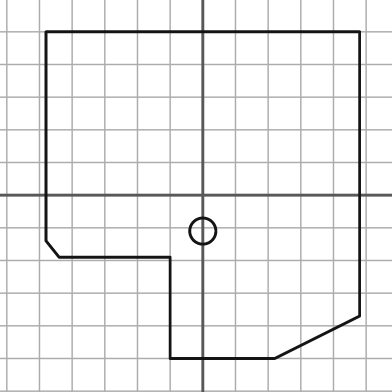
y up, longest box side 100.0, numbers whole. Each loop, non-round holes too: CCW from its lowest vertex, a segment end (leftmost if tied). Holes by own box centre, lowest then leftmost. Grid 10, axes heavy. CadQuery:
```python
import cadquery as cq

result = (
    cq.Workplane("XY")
    .moveTo(-10.0, -50.0)
    .lineTo(22.0, -50.0)
    .lineTo(48.0, -37.0)
    .lineTo(48.0, 50.0)
    .lineTo(-48.0, 50.0)
    .lineTo(-48.0, -14.0)
    .lineTo(-44.0, -19.0)
    .lineTo(-10.0, -19.0)
    .close()
    .moveTo(0.0, -11.0)
    .circle(4.0)
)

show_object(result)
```